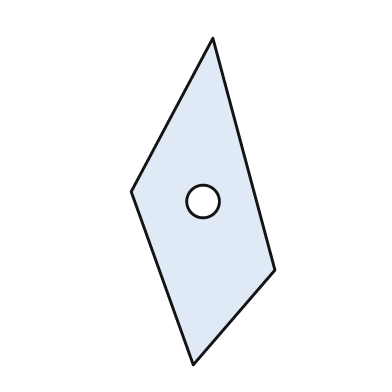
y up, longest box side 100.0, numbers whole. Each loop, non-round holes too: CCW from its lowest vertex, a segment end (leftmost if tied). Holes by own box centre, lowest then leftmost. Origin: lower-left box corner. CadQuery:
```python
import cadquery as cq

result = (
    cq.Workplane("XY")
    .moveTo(19.0, 0.0)
    .lineTo(44.0, 29.0)
    .lineTo(25.0, 100.0)
    .lineTo(0.0, 53.0)
    .close()
    .moveTo(22.0, 50.0)
    .circle(5.0)
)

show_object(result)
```